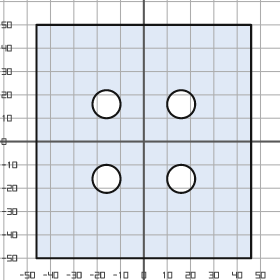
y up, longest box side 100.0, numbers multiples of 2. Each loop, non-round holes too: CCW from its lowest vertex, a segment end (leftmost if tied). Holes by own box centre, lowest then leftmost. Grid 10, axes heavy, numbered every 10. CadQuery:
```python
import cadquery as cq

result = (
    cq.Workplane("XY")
    .moveTo(-46.0, -50.0)
    .lineTo(46.0, -50.0)
    .lineTo(46.0, 50.0)
    .lineTo(-46.0, 50.0)
    .close()
    .moveTo(-16.0, -16.0)
    .circle(6.0)
    .moveTo(16.0, -16.0)
    .circle(6.0)
    .moveTo(-16.0, 16.0)
    .circle(6.0)
    .moveTo(16.0, 16.0)
    .circle(6.0)
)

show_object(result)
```